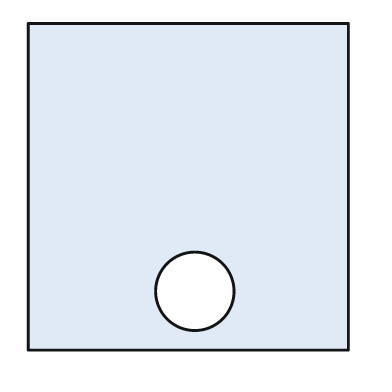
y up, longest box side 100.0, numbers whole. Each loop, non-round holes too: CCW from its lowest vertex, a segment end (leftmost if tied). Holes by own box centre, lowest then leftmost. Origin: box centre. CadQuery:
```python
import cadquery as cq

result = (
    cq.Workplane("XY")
    .moveTo(-49.0, -50.0)
    .lineTo(49.0, -50.0)
    .lineTo(49.0, 50.0)
    .lineTo(-49.0, 50.0)
    .close()
    .moveTo(2.0, -32.0)
    .circle(12.0)
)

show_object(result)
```